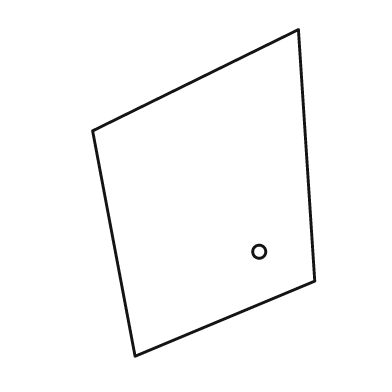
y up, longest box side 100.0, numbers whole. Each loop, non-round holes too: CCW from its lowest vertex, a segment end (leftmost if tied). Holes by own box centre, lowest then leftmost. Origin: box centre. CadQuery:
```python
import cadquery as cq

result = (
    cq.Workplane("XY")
    .moveTo(-21.0, -50.0)
    .lineTo(34.0, -27.0)
    .lineTo(29.0, 50.0)
    .lineTo(-34.0, 19.0)
    .close()
    .moveTo(17.0, -18.0)
    .circle(2.0)
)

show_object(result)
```